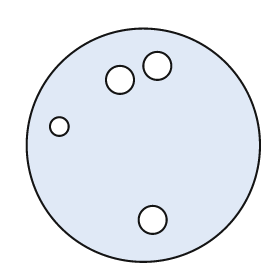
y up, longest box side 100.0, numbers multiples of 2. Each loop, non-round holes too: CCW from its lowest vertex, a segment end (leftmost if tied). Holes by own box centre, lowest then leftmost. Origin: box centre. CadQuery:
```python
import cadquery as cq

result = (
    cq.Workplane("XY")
    .moveTo(0.0, 0.0)
    .circle(50.0)
    .moveTo(4.0, -32.0)
    .circle(6.0)
    .moveTo(-36.0, 8.0)
    .circle(4.0)
    .moveTo(-10.0, 28.0)
    .circle(6.0)
    .moveTo(6.0, 34.0)
    .circle(6.0)
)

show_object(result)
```